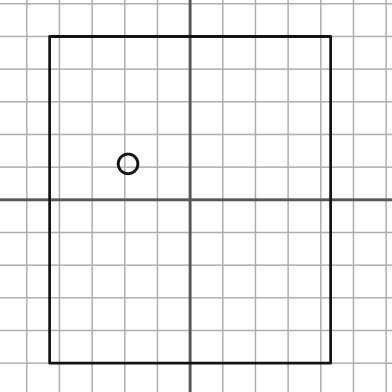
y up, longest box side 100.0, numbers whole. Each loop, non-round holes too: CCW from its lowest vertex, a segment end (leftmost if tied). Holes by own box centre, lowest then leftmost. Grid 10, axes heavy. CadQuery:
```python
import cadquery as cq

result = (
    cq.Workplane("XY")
    .moveTo(-43.0, -50.0)
    .lineTo(43.0, -50.0)
    .lineTo(43.0, 50.0)
    .lineTo(-43.0, 50.0)
    .close()
    .moveTo(-19.0, 11.0)
    .circle(3.0)
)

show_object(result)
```